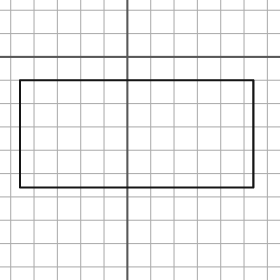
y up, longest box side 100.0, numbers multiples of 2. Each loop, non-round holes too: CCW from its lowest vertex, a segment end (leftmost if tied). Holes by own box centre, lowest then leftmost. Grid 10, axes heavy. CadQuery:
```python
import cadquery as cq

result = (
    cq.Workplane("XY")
    .moveTo(-46.0, -56.0)
    .lineTo(54.0, -56.0)
    .lineTo(54.0, -10.0)
    .lineTo(-46.0, -10.0)
    .close()
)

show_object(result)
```